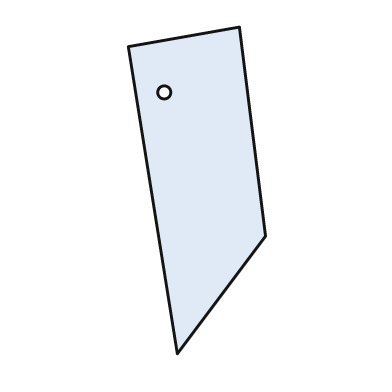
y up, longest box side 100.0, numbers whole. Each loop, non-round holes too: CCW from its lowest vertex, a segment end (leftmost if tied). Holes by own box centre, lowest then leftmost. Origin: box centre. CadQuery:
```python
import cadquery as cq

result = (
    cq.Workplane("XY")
    .moveTo(-6.0, -50.0)
    .lineTo(21.0, -14.0)
    .lineTo(13.0, 50.0)
    .lineTo(-21.0, 44.0)
    .close()
    .moveTo(-10.0, 30.0)
    .circle(2.0)
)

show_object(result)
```